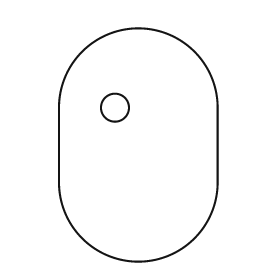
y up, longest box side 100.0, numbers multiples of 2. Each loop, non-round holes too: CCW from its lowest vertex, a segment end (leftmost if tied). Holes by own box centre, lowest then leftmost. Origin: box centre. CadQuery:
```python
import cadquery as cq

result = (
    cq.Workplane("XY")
    .moveTo(-34.0, -16.0)
    .threePointArc((0.0, -50.0), (34.0, -16.0))
    .lineTo(34.0, 16.0)
    .threePointArc((0.0, 50.0), (-34.0, 16.0))
    .close()
    .moveTo(-10.0, 16.0)
    .circle(6.0)
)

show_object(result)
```